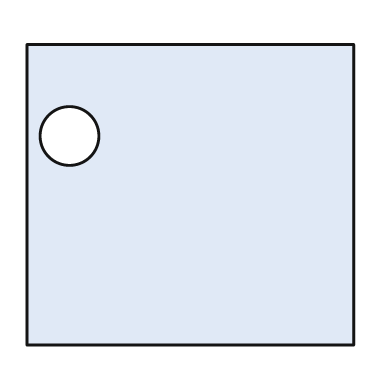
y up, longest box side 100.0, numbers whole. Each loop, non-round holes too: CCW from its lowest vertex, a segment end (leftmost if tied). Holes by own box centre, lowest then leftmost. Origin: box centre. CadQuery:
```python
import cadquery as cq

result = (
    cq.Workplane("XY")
    .moveTo(-50.0, -46.0)
    .lineTo(50.0, -46.0)
    .lineTo(50.0, 46.0)
    .lineTo(-50.0, 46.0)
    .close()
    .moveTo(-37.0, 18.0)
    .circle(9.0)
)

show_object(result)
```